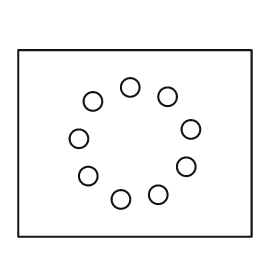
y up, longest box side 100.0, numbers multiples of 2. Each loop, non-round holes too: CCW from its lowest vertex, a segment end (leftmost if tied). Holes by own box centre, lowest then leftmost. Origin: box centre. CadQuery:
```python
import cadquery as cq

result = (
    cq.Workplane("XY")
    .moveTo(-50.0, -40.0)
    .lineTo(50.0, -40.0)
    .lineTo(50.0, 40.0)
    .lineTo(-50.0, 40.0)
    .close()
    .moveTo(-6.0, -24.0)
    .circle(4.0)
    .moveTo(10.0, -22.0)
    .circle(4.0)
    .moveTo(-20.0, -14.0)
    .circle(4.0)
    .moveTo(22.0, -10.0)
    .circle(4.0)
    .moveTo(-24.0, 2.0)
    .circle(4.0)
    .moveTo(24.0, 6.0)
    .circle(4.0)
    .moveTo(-18.0, 18.0)
    .circle(4.0)
    .moveTo(14.0, 20.0)
    .circle(4.0)
    .moveTo(-2.0, 24.0)
    .circle(4.0)
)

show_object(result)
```